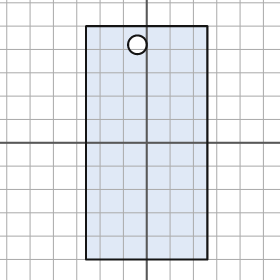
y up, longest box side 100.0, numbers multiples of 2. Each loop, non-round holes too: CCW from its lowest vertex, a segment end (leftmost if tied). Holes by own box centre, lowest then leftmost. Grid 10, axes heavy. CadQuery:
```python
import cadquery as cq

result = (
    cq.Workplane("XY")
    .moveTo(-26.0, -50.0)
    .lineTo(26.0, -50.0)
    .lineTo(26.0, 50.0)
    .lineTo(-26.0, 50.0)
    .close()
    .moveTo(-4.0, 42.0)
    .circle(4.0)
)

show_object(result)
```